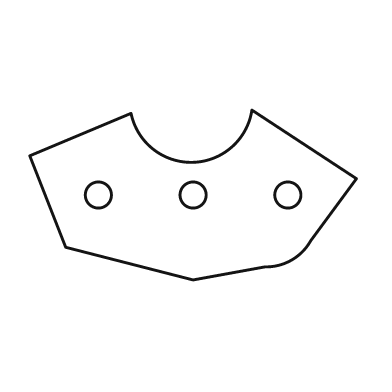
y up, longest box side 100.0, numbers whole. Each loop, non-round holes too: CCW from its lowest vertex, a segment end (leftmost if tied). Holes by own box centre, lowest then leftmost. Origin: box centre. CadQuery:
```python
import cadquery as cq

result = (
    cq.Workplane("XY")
    .moveTo(0.0, -26.0)
    .lineTo(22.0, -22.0)
    .threePointArc((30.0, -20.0), (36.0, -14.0))
    .lineTo(50.0, 5.0)
    .lineTo(18.0, 26.0)
    .threePointArc((0.0, 10.0), (-19.0, 25.0))
    .lineTo(-50.0, 12.0)
    .lineTo(-39.0, -16.0)
    .close()
    .moveTo(-29.0, 0.0)
    .circle(4.0)
    .moveTo(0.0, 0.0)
    .circle(4.0)
    .moveTo(29.0, 0.0)
    .circle(4.0)
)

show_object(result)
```